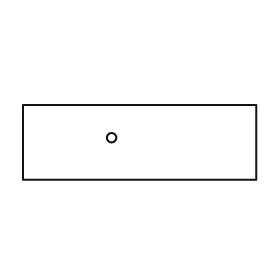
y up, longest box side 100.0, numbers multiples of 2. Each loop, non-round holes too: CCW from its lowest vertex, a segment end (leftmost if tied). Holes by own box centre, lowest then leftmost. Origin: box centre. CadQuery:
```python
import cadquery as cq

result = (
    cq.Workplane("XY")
    .moveTo(-50.0, -16.0)
    .lineTo(50.0, -16.0)
    .lineTo(50.0, 16.0)
    .lineTo(-50.0, 16.0)
    .close()
    .moveTo(-12.0, 2.0)
    .circle(2.0)
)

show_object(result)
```